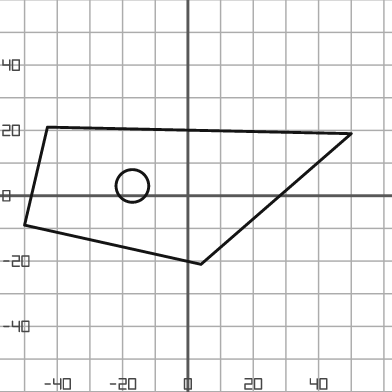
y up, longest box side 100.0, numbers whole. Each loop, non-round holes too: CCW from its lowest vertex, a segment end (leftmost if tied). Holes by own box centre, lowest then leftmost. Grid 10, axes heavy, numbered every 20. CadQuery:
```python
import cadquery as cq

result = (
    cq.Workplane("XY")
    .moveTo(4.0, -21.0)
    .lineTo(50.0, 19.0)
    .lineTo(-43.0, 21.0)
    .lineTo(-50.0, -9.0)
    .close()
    .moveTo(-17.0, 3.0)
    .circle(5.0)
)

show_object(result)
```